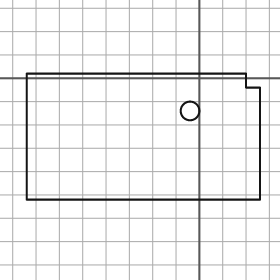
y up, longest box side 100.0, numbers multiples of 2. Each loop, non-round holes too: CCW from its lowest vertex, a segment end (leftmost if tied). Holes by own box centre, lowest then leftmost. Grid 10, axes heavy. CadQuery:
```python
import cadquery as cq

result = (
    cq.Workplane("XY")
    .moveTo(-74.0, -52.0)
    .lineTo(26.0, -52.0)
    .lineTo(26.0, -4.0)
    .lineTo(20.0, -4.0)
    .lineTo(20.0, 2.0)
    .lineTo(-74.0, 2.0)
    .close()
    .moveTo(-4.0, -14.0)
    .circle(4.0)
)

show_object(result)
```